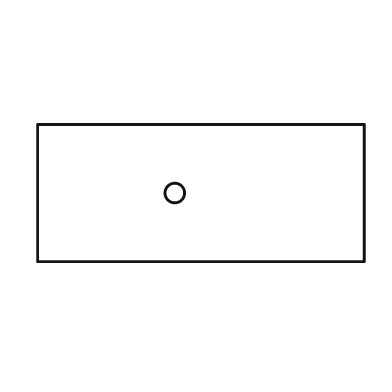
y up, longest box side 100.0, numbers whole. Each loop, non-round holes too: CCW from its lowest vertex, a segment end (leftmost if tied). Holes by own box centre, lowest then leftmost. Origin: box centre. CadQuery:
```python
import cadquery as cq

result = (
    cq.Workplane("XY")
    .moveTo(-50.0, -21.0)
    .lineTo(50.0, -21.0)
    .lineTo(50.0, 21.0)
    .lineTo(-50.0, 21.0)
    .close()
    .moveTo(-8.0, 0.0)
    .circle(3.0)
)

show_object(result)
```